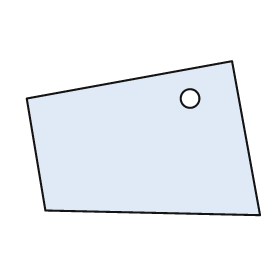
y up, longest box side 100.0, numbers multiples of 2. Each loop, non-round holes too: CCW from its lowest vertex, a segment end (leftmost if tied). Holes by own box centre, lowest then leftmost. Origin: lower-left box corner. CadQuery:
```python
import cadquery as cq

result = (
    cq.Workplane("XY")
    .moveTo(100.0, 0.0)
    .lineTo(88.0, 66.0)
    .lineTo(0.0, 50.0)
    .lineTo(8.0, 2.0)
    .close()
    .moveTo(70.0, 50.0)
    .circle(4.0)
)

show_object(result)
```